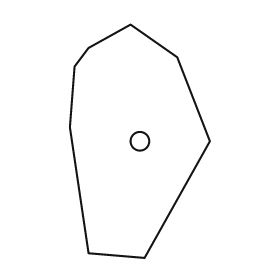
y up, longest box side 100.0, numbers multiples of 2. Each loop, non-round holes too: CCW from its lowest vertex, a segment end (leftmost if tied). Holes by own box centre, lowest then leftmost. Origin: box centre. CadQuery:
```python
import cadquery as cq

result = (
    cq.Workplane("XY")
    .moveTo(2.0, -50.0)
    .lineTo(30.0, 0.0)
    .lineTo(16.0, 36.0)
    .lineTo(-4.0, 50.0)
    .lineTo(-22.0, 40.0)
    .lineTo(-28.0, 32.0)
    .lineTo(-30.0, 6.0)
    .lineTo(-22.0, -48.0)
    .close()
    .moveTo(0.0, 0.0)
    .circle(4.0)
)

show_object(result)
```